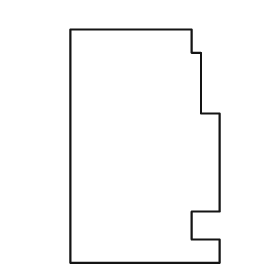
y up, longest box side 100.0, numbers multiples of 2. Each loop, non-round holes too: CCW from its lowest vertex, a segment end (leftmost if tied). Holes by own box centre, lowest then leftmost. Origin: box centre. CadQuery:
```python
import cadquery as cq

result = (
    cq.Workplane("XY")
    .moveTo(-32.0, -50.0)
    .lineTo(32.0, -50.0)
    .lineTo(32.0, -40.0)
    .lineTo(20.0, -40.0)
    .lineTo(20.0, -28.0)
    .lineTo(32.0, -28.0)
    .lineTo(32.0, 14.0)
    .lineTo(24.0, 14.0)
    .lineTo(24.0, 40.0)
    .lineTo(20.0, 40.0)
    .lineTo(20.0, 50.0)
    .lineTo(-32.0, 50.0)
    .close()
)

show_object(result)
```